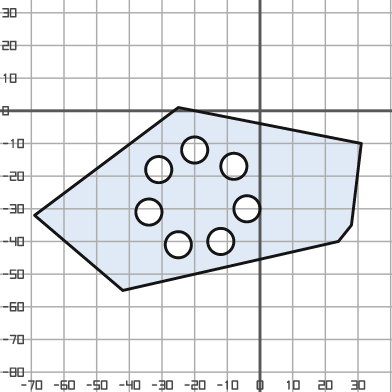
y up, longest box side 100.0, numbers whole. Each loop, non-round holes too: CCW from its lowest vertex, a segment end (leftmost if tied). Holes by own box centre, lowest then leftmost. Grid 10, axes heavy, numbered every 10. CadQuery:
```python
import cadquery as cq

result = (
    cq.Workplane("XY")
    .moveTo(-42.0, -55.0)
    .lineTo(24.0, -40.0)
    .lineTo(28.0, -35.0)
    .lineTo(31.0, -10.0)
    .lineTo(-25.0, 1.0)
    .lineTo(-69.0, -32.0)
    .close()
    .moveTo(-25.0, -41.0)
    .circle(4.0)
    .moveTo(-12.0, -40.0)
    .circle(4.0)
    .moveTo(-34.0, -31.0)
    .circle(4.0)
    .moveTo(-4.0, -30.0)
    .circle(4.0)
    .moveTo(-31.0, -18.0)
    .circle(4.0)
    .moveTo(-8.0, -17.0)
    .circle(4.0)
    .moveTo(-20.0, -12.0)
    .circle(4.0)
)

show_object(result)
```